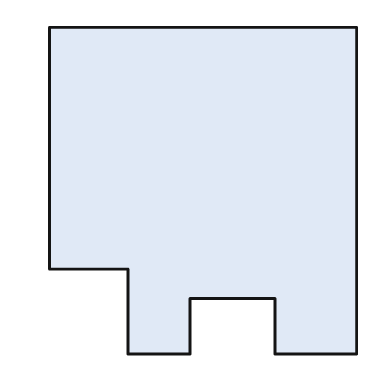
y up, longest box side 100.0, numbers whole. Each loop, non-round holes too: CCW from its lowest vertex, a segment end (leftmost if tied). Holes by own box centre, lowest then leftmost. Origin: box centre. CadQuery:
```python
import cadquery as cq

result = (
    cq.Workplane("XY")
    .moveTo(-23.0, -50.0)
    .lineTo(-4.0, -50.0)
    .lineTo(-4.0, -33.0)
    .lineTo(22.0, -33.0)
    .lineTo(22.0, -50.0)
    .lineTo(47.0, -50.0)
    .lineTo(47.0, 50.0)
    .lineTo(-47.0, 50.0)
    .lineTo(-47.0, -24.0)
    .lineTo(-23.0, -24.0)
    .close()
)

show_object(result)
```